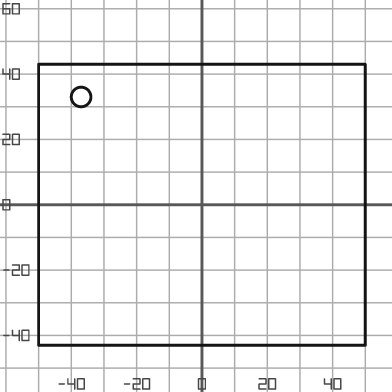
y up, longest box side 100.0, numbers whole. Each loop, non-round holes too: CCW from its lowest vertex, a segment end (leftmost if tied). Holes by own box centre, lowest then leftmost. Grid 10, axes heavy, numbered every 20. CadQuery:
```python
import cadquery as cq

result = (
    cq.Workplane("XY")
    .moveTo(-50.0, -43.0)
    .lineTo(50.0, -43.0)
    .lineTo(50.0, 43.0)
    .lineTo(-50.0, 43.0)
    .close()
    .moveTo(-37.0, 33.0)
    .circle(3.0)
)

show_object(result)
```